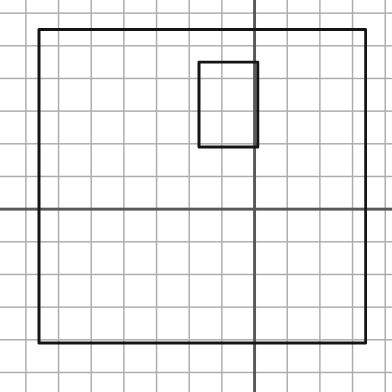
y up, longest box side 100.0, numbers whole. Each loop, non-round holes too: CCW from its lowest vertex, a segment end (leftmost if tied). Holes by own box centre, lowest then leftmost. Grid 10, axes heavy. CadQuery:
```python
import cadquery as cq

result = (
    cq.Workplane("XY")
    .moveTo(-66.0, -41.0)
    .lineTo(34.0, -41.0)
    .lineTo(34.0, 55.0)
    .lineTo(-66.0, 55.0)
    .close()
    .moveTo(-17.0, 19.0)
    .lineTo(1.0, 19.0)
    .lineTo(1.0, 45.0)
    .lineTo(-17.0, 45.0)
    .close()
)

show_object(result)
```